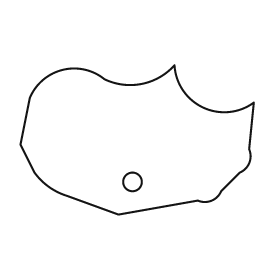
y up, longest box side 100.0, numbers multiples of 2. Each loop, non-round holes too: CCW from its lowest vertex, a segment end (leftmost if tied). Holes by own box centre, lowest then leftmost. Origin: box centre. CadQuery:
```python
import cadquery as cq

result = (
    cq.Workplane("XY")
    .moveTo(-8.0, -32.0)
    .lineTo(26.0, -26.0)
    .threePointArc((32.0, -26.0), (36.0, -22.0))
    .lineTo(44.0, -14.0)
    .threePointArc((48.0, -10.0), (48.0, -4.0))
    .lineTo(50.0, 16.0)
    .threePointArc((28.0, 14.0), (16.0, 32.0))
    .threePointArc((2.0, 24.0), (-14.0, 26.0))
    .threePointArc((-32.0, 30.0), (-46.0, 18.0))
    .lineTo(-50.0, -2.0)
    .lineTo(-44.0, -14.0)
    .threePointArc((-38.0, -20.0), (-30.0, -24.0))
    .close()
    .moveTo(-2.0, -18.0)
    .circle(4.0)
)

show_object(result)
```